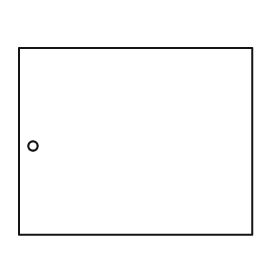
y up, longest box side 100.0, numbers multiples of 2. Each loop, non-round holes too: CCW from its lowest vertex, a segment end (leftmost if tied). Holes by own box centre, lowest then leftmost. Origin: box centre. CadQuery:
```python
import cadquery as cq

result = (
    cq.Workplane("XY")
    .moveTo(-50.0, -40.0)
    .lineTo(50.0, -40.0)
    .lineTo(50.0, 40.0)
    .lineTo(-50.0, 40.0)
    .close()
    .moveTo(-44.0, -2.0)
    .circle(2.0)
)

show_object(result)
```